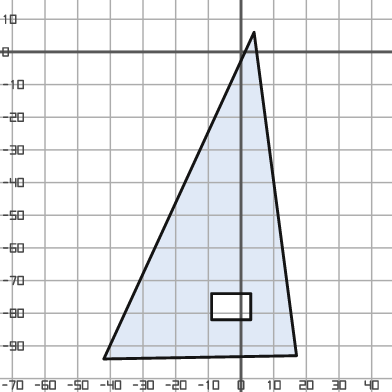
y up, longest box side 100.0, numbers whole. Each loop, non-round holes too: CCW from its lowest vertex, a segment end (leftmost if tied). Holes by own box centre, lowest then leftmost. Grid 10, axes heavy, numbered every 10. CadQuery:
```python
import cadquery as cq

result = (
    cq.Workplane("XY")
    .moveTo(-42.0, -94.0)
    .lineTo(17.0, -93.0)
    .lineTo(4.0, 6.0)
    .close()
    .moveTo(-9.0, -82.0)
    .lineTo(3.0, -82.0)
    .lineTo(3.0, -74.0)
    .lineTo(-9.0, -74.0)
    .close()
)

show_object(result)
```